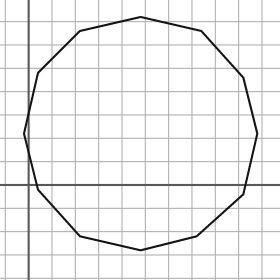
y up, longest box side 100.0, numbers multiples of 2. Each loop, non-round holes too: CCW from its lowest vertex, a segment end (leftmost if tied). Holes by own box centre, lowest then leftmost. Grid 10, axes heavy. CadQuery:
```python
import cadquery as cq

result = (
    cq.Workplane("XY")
    .moveTo(48.0, -28.0)
    .lineTo(72.0, -22.0)
    .lineTo(92.0, -4.0)
    .lineTo(98.0, 22.0)
    .lineTo(92.0, 46.0)
    .lineTo(74.0, 66.0)
    .lineTo(48.0, 72.0)
    .lineTo(22.0, 66.0)
    .lineTo(4.0, 48.0)
    .lineTo(-2.0, 22.0)
    .lineTo(4.0, -2.0)
    .lineTo(22.0, -22.0)
    .close()
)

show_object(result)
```